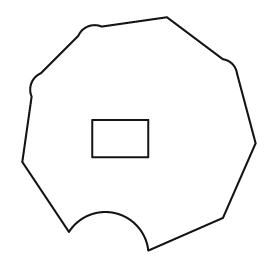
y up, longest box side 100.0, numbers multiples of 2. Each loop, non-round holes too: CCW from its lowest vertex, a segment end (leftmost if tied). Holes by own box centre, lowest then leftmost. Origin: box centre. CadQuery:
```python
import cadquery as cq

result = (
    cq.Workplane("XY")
    .moveTo(4.0, -50.0)
    .lineTo(36.0, -36.0)
    .lineTo(50.0, -4.0)
    .lineTo(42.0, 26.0)
    .threePointArc((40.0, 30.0), (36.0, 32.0))
    .lineTo(12.0, 50.0)
    .lineTo(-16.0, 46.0)
    .threePointArc((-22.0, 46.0), (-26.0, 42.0))
    .lineTo(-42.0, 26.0)
    .threePointArc((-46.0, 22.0), (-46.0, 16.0))
    .lineTo(-50.0, -12.0)
    .lineTo(-30.0, -42.0)
    .threePointArc((-10.0, -34.0), (4.0, -50.0))
    .close()
    .moveTo(-20.0, -10.0)
    .lineTo(4.0, -10.0)
    .lineTo(4.0, 6.0)
    .lineTo(-20.0, 6.0)
    .close()
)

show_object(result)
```